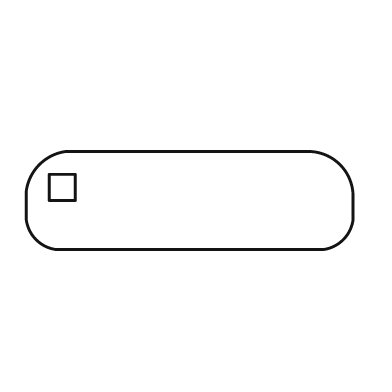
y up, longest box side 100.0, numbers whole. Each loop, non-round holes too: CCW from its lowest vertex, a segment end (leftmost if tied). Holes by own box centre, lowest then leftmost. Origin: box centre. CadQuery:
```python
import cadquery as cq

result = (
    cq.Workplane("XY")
    .moveTo(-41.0, -15.0)
    .lineTo(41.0, -15.0)
    .threePointArc((47.0, -12.0), (50.0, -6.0))
    .lineTo(50.0, 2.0)
    .threePointArc((46.0, 11.0), (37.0, 15.0))
    .lineTo(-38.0, 15.0)
    .threePointArc((-46.0, 11.0), (-50.0, 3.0))
    .lineTo(-50.0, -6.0)
    .threePointArc((-47.0, -12.0), (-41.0, -15.0))
    .close()
    .moveTo(-43.0, 0.0)
    .lineTo(-35.0, 0.0)
    .lineTo(-35.0, 8.0)
    .lineTo(-43.0, 8.0)
    .close()
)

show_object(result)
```